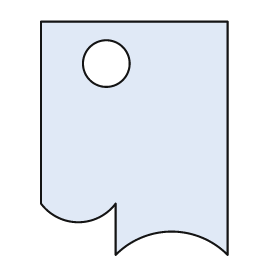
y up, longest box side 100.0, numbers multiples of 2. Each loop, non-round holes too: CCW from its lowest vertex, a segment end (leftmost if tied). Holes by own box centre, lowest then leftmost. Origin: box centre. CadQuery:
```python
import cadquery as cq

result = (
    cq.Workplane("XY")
    .moveTo(-8.0, -50.0)
    .threePointArc((16.0, -40.0), (40.0, -50.0))
    .lineTo(40.0, 50.0)
    .lineTo(-40.0, 50.0)
    .lineTo(-40.0, -28.0)
    .threePointArc((-24.0, -36.0), (-8.0, -28.0))
    .close()
    .moveTo(-12.0, 32.0)
    .circle(10.0)
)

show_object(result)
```